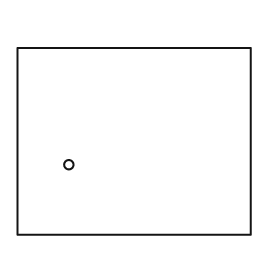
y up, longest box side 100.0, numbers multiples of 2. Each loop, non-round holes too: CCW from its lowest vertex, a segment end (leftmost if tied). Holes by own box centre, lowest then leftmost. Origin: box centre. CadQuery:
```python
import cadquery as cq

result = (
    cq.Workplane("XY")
    .moveTo(-50.0, -40.0)
    .lineTo(50.0, -40.0)
    .lineTo(50.0, 40.0)
    .lineTo(-50.0, 40.0)
    .close()
    .moveTo(-28.0, -10.0)
    .circle(2.0)
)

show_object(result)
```